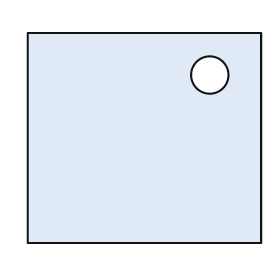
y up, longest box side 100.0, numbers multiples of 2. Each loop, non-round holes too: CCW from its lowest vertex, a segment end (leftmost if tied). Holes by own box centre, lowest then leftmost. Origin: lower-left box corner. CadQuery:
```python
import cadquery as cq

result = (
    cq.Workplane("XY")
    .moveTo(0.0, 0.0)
    .lineTo(100.0, 0.0)
    .lineTo(100.0, 90.0)
    .lineTo(0.0, 90.0)
    .close()
    .moveTo(78.0, 72.0)
    .circle(8.0)
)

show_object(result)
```